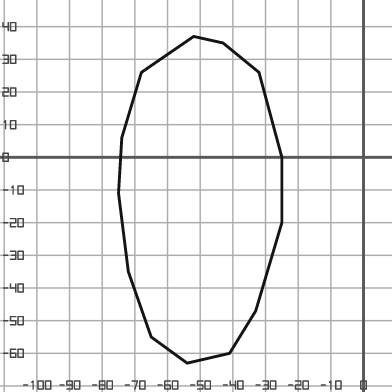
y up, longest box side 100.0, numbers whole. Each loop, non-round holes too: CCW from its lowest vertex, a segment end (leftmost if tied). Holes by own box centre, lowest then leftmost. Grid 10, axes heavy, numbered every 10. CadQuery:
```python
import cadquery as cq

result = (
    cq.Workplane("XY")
    .moveTo(-54.0, -63.0)
    .lineTo(-41.0, -60.0)
    .lineTo(-33.0, -47.0)
    .lineTo(-25.0, -20.0)
    .lineTo(-25.0, 0.0)
    .lineTo(-32.0, 26.0)
    .lineTo(-43.0, 35.0)
    .lineTo(-52.0, 37.0)
    .lineTo(-68.0, 26.0)
    .lineTo(-74.0, 6.0)
    .lineTo(-75.0, -11.0)
    .lineTo(-72.0, -35.0)
    .lineTo(-65.0, -55.0)
    .close()
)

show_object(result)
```